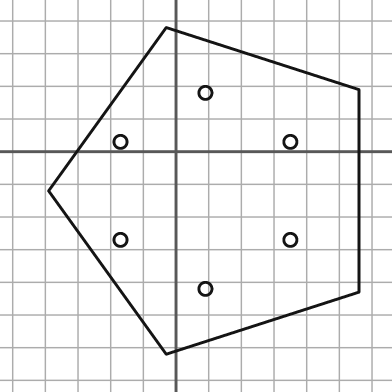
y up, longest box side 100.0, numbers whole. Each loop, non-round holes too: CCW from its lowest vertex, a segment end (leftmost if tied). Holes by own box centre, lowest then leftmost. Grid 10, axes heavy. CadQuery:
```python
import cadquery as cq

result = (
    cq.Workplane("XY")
    .moveTo(-3.0, -62.0)
    .lineTo(56.0, -43.0)
    .lineTo(56.0, 19.0)
    .lineTo(-3.0, 38.0)
    .lineTo(-39.0, -12.0)
    .close()
    .moveTo(9.0, -42.0)
    .circle(2.0)
    .moveTo(-17.0, -27.0)
    .circle(2.0)
    .moveTo(35.0, -27.0)
    .circle(2.0)
    .moveTo(-17.0, 3.0)
    .circle(2.0)
    .moveTo(35.0, 3.0)
    .circle(2.0)
    .moveTo(9.0, 18.0)
    .circle(2.0)
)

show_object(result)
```